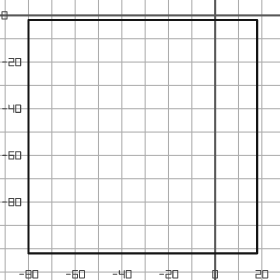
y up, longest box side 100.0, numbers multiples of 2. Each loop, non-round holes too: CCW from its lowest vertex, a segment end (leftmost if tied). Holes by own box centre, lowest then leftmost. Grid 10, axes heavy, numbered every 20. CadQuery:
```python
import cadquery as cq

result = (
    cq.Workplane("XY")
    .moveTo(-80.0, -102.0)
    .lineTo(18.0, -102.0)
    .lineTo(18.0, -2.0)
    .lineTo(-80.0, -2.0)
    .close()
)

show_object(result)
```